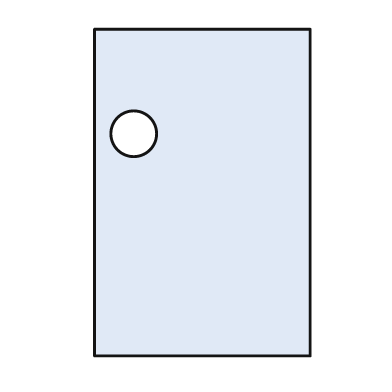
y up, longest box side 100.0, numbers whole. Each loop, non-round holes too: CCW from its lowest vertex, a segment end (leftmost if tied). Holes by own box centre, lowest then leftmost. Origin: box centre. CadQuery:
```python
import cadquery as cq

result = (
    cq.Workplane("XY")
    .moveTo(-33.0, -50.0)
    .lineTo(33.0, -50.0)
    .lineTo(33.0, 50.0)
    .lineTo(-33.0, 50.0)
    .close()
    .moveTo(-21.0, 18.0)
    .circle(7.0)
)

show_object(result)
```